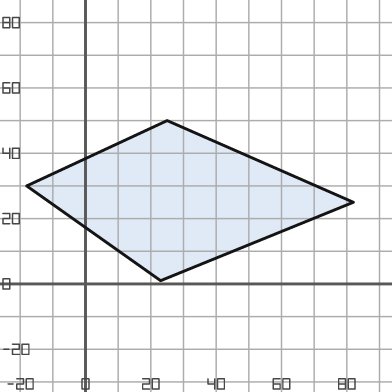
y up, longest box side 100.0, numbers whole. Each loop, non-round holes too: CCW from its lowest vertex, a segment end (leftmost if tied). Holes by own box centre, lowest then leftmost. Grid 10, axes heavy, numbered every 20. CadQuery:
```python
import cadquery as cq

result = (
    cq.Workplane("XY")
    .moveTo(23.0, 1.0)
    .lineTo(82.0, 25.0)
    .lineTo(25.0, 50.0)
    .lineTo(-18.0, 30.0)
    .close()
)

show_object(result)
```